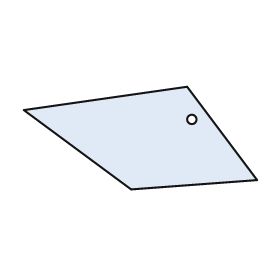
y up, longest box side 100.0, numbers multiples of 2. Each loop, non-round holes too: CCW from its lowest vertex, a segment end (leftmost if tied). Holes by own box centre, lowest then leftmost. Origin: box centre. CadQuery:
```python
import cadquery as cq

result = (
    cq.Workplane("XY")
    .moveTo(-4.0, -22.0)
    .lineTo(50.0, -18.0)
    .lineTo(20.0, 22.0)
    .lineTo(-50.0, 12.0)
    .close()
    .moveTo(22.0, 8.0)
    .circle(2.0)
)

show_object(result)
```